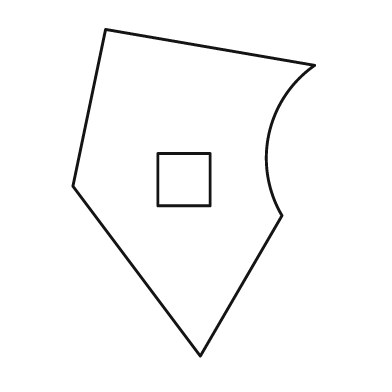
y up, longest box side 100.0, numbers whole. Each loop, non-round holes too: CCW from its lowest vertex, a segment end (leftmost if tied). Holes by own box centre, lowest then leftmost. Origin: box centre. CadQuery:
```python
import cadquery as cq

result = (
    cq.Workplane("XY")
    .moveTo(2.0, -50.0)
    .lineTo(27.0, -7.0)
    .threePointArc((23.0, 18.0), (37.0, 39.0))
    .lineTo(-27.0, 50.0)
    .lineTo(-37.0, 2.0)
    .close()
    .moveTo(-11.0, -4.0)
    .lineTo(5.0, -4.0)
    .lineTo(5.0, 12.0)
    .lineTo(-11.0, 12.0)
    .close()
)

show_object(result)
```